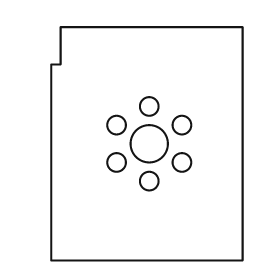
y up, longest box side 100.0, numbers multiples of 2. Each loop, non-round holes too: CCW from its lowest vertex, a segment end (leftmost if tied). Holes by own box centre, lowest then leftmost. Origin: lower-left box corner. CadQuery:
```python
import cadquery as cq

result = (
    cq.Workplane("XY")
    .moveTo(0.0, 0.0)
    .lineTo(82.0, 0.0)
    .lineTo(82.0, 100.0)
    .lineTo(4.0, 100.0)
    .lineTo(4.0, 84.0)
    .lineTo(0.0, 84.0)
    .close()
    .moveTo(42.0, 34.0)
    .circle(4.0)
    .moveTo(28.0, 42.0)
    .circle(4.0)
    .moveTo(56.0, 42.0)
    .circle(4.0)
    .moveTo(42.0, 50.0)
    .circle(8.0)
    .moveTo(28.0, 58.0)
    .circle(4.0)
    .moveTo(56.0, 58.0)
    .circle(4.0)
    .moveTo(42.0, 66.0)
    .circle(4.0)
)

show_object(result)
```